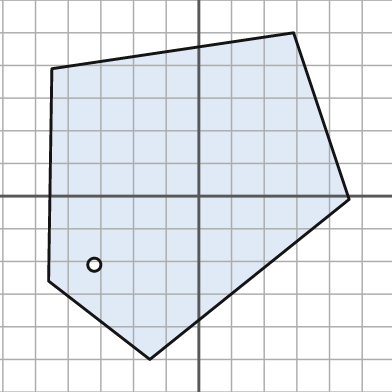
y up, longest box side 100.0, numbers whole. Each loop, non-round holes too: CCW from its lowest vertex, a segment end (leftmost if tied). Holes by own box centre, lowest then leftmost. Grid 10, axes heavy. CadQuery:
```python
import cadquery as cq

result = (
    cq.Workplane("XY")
    .moveTo(-15.0, -50.0)
    .lineTo(46.0, -1.0)
    .lineTo(29.0, 50.0)
    .lineTo(-45.0, 39.0)
    .lineTo(-46.0, -26.0)
    .close()
    .moveTo(-32.0, -21.0)
    .circle(2.0)
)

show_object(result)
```